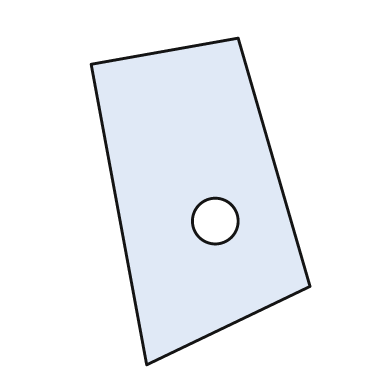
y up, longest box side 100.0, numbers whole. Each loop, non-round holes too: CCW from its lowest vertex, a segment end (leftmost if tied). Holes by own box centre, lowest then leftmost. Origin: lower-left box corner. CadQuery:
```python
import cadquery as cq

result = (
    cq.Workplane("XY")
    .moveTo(17.0, 0.0)
    .lineTo(67.0, 24.0)
    .lineTo(45.0, 100.0)
    .lineTo(0.0, 92.0)
    .close()
    .moveTo(38.0, 44.0)
    .circle(7.0)
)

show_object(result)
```